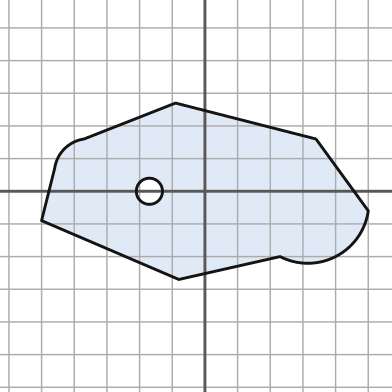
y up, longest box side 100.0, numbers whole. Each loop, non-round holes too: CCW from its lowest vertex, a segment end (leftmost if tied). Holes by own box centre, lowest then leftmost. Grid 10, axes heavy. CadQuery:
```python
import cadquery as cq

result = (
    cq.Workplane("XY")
    .moveTo(-8.0, -27.0)
    .lineTo(23.0, -20.0)
    .threePointArc((40.0, -20.0), (50.0, -6.0))
    .lineTo(34.0, 16.0)
    .lineTo(-9.0, 27.0)
    .lineTo(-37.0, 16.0)
    .threePointArc((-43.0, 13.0), (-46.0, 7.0))
    .lineTo(-50.0, -9.0)
    .close()
    .moveTo(-17.0, 0.0)
    .circle(4.0)
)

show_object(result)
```